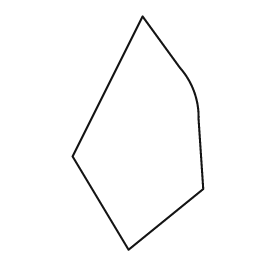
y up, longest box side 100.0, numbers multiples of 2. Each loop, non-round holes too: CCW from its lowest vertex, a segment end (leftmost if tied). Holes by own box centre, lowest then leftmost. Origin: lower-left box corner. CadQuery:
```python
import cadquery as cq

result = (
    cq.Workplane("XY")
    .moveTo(24.0, 0.0)
    .lineTo(56.0, 26.0)
    .lineTo(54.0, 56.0)
    .threePointArc((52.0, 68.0), (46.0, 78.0))
    .lineTo(30.0, 100.0)
    .lineTo(0.0, 40.0)
    .close()
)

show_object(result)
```